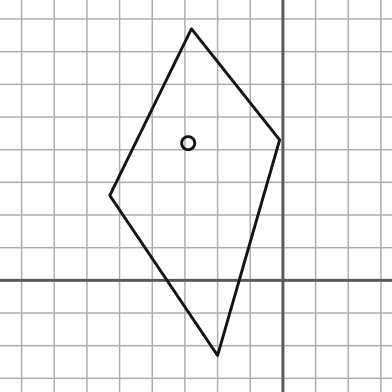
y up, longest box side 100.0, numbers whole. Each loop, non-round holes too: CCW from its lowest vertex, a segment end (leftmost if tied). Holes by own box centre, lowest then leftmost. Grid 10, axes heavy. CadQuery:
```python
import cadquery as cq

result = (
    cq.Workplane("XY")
    .moveTo(-20.0, -23.0)
    .lineTo(-1.0, 43.0)
    .lineTo(-28.0, 77.0)
    .lineTo(-53.0, 26.0)
    .close()
    .moveTo(-29.0, 42.0)
    .circle(2.0)
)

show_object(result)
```